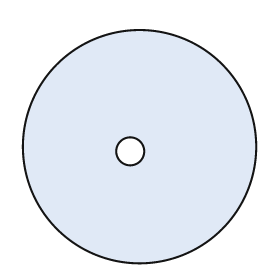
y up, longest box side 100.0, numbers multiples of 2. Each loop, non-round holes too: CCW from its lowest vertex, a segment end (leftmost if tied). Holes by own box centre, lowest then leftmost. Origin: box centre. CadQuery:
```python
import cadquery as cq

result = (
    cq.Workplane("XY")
    .moveTo(0.0, 0.0)
    .circle(50.0)
    .moveTo(-4.0, -2.0)
    .circle(6.0)
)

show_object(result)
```